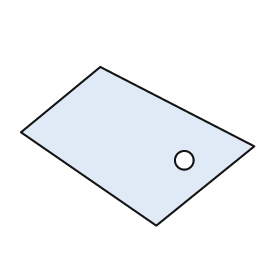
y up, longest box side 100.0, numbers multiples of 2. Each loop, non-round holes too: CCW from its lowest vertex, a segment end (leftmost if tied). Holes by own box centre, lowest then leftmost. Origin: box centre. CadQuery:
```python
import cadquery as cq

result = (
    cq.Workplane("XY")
    .moveTo(8.0, -34.0)
    .lineTo(50.0, 0.0)
    .lineTo(-16.0, 34.0)
    .lineTo(-50.0, 6.0)
    .close()
    .moveTo(20.0, -6.0)
    .circle(4.0)
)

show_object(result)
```